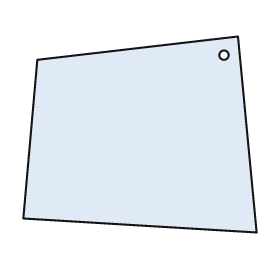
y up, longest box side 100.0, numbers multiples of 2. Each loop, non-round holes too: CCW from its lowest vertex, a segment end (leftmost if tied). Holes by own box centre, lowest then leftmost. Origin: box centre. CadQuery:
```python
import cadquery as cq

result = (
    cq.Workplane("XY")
    .moveTo(50.0, -42.0)
    .lineTo(42.0, 42.0)
    .lineTo(-44.0, 32.0)
    .lineTo(-50.0, -36.0)
    .close()
    .moveTo(36.0, 34.0)
    .circle(2.0)
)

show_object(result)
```